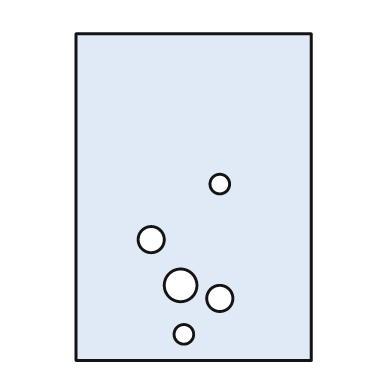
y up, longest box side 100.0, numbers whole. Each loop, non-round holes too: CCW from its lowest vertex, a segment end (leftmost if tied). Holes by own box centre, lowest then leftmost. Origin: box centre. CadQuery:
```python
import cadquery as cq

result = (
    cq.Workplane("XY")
    .moveTo(-36.0, -50.0)
    .lineTo(36.0, -50.0)
    .lineTo(36.0, 50.0)
    .lineTo(-36.0, 50.0)
    .close()
    .moveTo(-3.0, -42.0)
    .circle(3.0)
    .moveTo(8.0, -31.0)
    .circle(4.0)
    .moveTo(-4.0, -27.0)
    .circle(5.0)
    .moveTo(-13.0, -13.0)
    .circle(4.0)
    .moveTo(8.0, 4.0)
    .circle(3.0)
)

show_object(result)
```